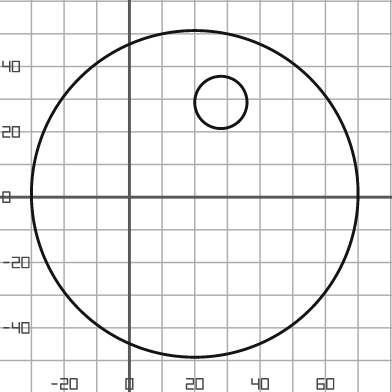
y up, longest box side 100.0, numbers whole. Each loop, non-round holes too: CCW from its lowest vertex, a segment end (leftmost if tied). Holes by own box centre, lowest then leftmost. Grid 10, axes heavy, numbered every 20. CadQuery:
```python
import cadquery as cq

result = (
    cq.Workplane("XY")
    .moveTo(20.0, 1.0)
    .circle(50.0)
    .moveTo(28.0, 29.0)
    .circle(8.0)
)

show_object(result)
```